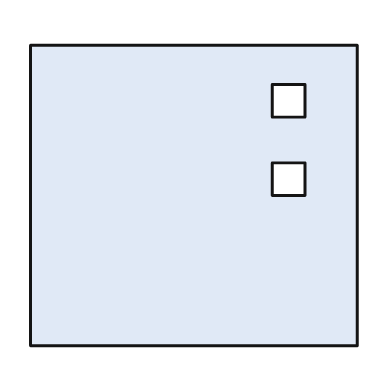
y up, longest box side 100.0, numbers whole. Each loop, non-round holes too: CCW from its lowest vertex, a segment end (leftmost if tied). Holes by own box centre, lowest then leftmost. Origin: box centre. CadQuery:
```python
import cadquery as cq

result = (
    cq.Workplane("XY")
    .moveTo(-50.0, -46.0)
    .lineTo(50.0, -46.0)
    .lineTo(50.0, 46.0)
    .lineTo(-50.0, 46.0)
    .close()
    .moveTo(24.0, 0.0)
    .lineTo(34.0, 0.0)
    .lineTo(34.0, 10.0)
    .lineTo(24.0, 10.0)
    .close()
    .moveTo(24.0, 24.0)
    .lineTo(34.0, 24.0)
    .lineTo(34.0, 34.0)
    .lineTo(24.0, 34.0)
    .close()
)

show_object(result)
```